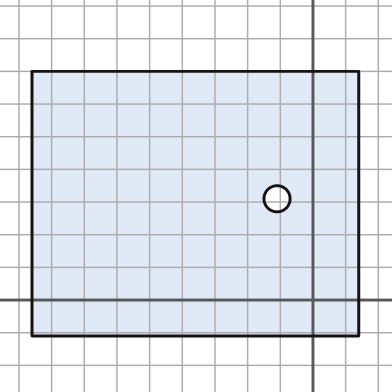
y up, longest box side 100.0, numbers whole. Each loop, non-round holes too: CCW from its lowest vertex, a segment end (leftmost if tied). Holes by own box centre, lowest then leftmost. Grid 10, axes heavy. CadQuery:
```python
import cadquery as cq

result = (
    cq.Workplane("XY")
    .moveTo(-86.0, -11.0)
    .lineTo(14.0, -11.0)
    .lineTo(14.0, 70.0)
    .lineTo(-86.0, 70.0)
    .close()
    .moveTo(-11.0, 31.0)
    .circle(4.0)
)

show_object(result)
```